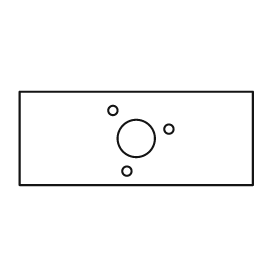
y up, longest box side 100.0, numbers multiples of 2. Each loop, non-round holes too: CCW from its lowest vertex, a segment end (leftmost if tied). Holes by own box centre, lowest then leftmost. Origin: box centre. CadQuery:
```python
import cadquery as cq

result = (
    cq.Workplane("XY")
    .moveTo(-50.0, -20.0)
    .lineTo(50.0, -20.0)
    .lineTo(50.0, 20.0)
    .lineTo(-50.0, 20.0)
    .close()
    .moveTo(-4.0, -14.0)
    .circle(2.0)
    .moveTo(0.0, 0.0)
    .circle(8.0)
    .moveTo(14.0, 4.0)
    .circle(2.0)
    .moveTo(-10.0, 12.0)
    .circle(2.0)
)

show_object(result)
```